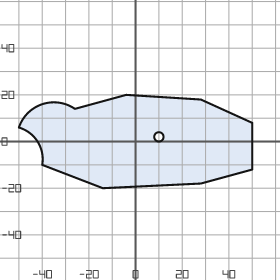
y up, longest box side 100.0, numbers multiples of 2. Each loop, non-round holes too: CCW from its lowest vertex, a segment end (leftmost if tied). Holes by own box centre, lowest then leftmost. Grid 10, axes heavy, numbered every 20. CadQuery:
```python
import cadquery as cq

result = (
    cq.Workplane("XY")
    .moveTo(-14.0, -20.0)
    .lineTo(28.0, -18.0)
    .lineTo(50.0, -12.0)
    .lineTo(50.0, 8.0)
    .lineTo(28.0, 18.0)
    .lineTo(-4.0, 20.0)
    .lineTo(-26.0, 14.0)
    .threePointArc((-40.0, 16.0), (-50.0, 6.0))
    .threePointArc((-42.0, 0.0), (-40.0, -10.0))
    .close()
    .moveTo(10.0, 2.0)
    .circle(2.0)
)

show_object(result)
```